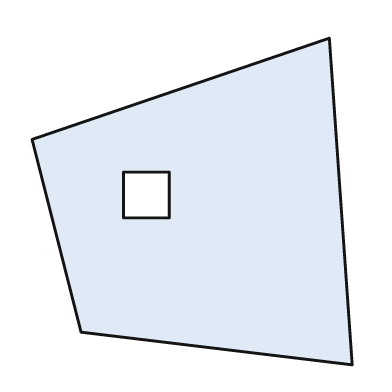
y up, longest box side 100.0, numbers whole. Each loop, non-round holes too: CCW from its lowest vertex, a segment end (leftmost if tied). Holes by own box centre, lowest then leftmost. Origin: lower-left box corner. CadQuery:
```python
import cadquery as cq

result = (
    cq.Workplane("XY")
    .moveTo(98.0, 0.0)
    .lineTo(91.0, 100.0)
    .lineTo(0.0, 69.0)
    .lineTo(15.0, 10.0)
    .close()
    .moveTo(28.0, 45.0)
    .lineTo(42.0, 45.0)
    .lineTo(42.0, 59.0)
    .lineTo(28.0, 59.0)
    .close()
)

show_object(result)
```